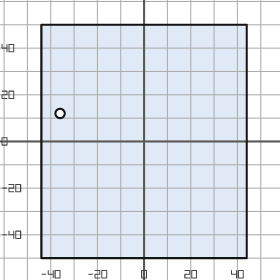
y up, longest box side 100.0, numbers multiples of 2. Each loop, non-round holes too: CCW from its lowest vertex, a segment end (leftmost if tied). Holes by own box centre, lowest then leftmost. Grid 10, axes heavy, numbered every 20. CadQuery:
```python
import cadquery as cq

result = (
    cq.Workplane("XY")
    .moveTo(-44.0, -50.0)
    .lineTo(44.0, -50.0)
    .lineTo(44.0, 50.0)
    .lineTo(-44.0, 50.0)
    .close()
    .moveTo(-36.0, 12.0)
    .circle(2.0)
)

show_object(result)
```